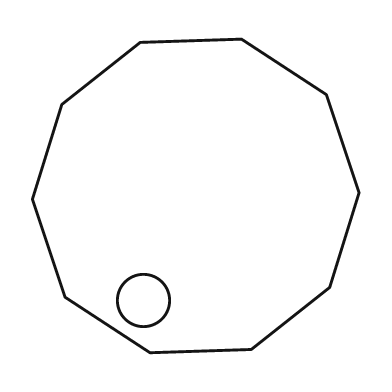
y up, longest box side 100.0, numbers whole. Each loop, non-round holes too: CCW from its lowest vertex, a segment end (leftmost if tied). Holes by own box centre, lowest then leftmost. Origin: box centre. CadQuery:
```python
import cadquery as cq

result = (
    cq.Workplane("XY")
    .moveTo(-14.0, -48.0)
    .lineTo(17.0, -47.0)
    .lineTo(41.0, -28.0)
    .lineTo(50.0, 1.0)
    .lineTo(40.0, 31.0)
    .lineTo(14.0, 48.0)
    .lineTo(-17.0, 47.0)
    .lineTo(-41.0, 28.0)
    .lineTo(-50.0, -1.0)
    .lineTo(-40.0, -31.0)
    .close()
    .moveTo(-16.0, -32.0)
    .circle(8.0)
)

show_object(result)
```